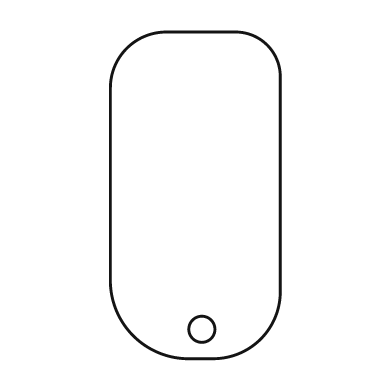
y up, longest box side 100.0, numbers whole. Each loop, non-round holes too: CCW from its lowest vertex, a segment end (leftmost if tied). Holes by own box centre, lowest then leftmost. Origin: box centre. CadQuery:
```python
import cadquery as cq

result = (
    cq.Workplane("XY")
    .moveTo(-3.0, -50.0)
    .lineTo(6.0, -50.0)
    .threePointArc((20.0, -44.0), (26.0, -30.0))
    .lineTo(26.0, 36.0)
    .threePointArc((22.0, 46.0), (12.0, 50.0))
    .lineTo(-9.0, 50.0)
    .threePointArc((-21.0, 45.0), (-26.0, 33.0))
    .lineTo(-26.0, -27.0)
    .threePointArc((-19.0, -43.0), (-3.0, -50.0))
    .close()
    .moveTo(2.0, -41.0)
    .circle(4.0)
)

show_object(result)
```